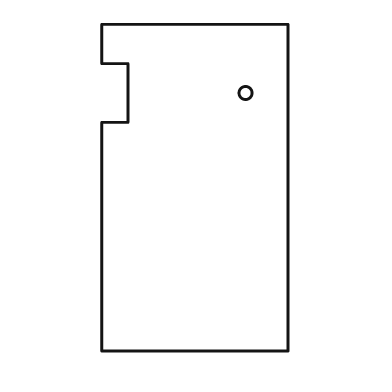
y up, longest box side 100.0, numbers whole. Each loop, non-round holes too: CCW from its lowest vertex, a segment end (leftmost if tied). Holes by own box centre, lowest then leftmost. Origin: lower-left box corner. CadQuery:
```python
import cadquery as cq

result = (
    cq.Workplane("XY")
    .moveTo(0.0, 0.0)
    .lineTo(57.0, 0.0)
    .lineTo(57.0, 100.0)
    .lineTo(0.0, 100.0)
    .lineTo(0.0, 88.0)
    .lineTo(8.0, 88.0)
    .lineTo(8.0, 70.0)
    .lineTo(0.0, 70.0)
    .close()
    .moveTo(44.0, 79.0)
    .circle(2.0)
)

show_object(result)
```